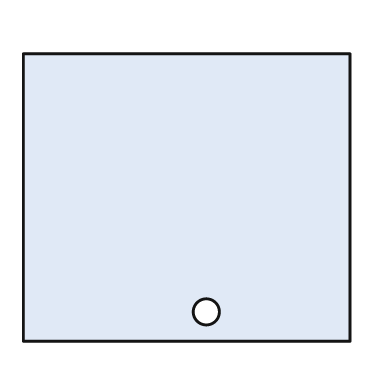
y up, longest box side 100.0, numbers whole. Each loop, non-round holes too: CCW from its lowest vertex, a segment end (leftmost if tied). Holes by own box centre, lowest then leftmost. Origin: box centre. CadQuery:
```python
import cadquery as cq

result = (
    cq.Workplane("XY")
    .moveTo(-50.0, -44.0)
    .lineTo(50.0, -44.0)
    .lineTo(50.0, 44.0)
    .lineTo(-50.0, 44.0)
    .close()
    .moveTo(6.0, -35.0)
    .circle(4.0)
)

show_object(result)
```